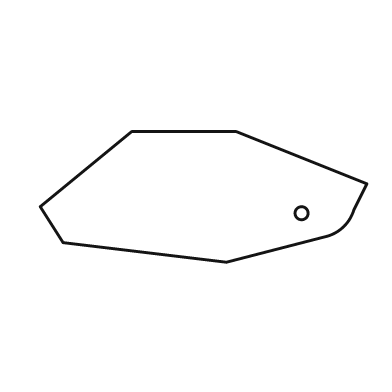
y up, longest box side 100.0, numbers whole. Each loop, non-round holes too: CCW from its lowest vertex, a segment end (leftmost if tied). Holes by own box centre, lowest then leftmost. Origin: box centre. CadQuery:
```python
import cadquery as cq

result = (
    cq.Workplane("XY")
    .moveTo(7.0, -20.0)
    .lineTo(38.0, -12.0)
    .threePointArc((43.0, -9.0), (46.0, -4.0))
    .lineTo(50.0, 4.0)
    .lineTo(10.0, 20.0)
    .lineTo(-22.0, 20.0)
    .lineTo(-50.0, -3.0)
    .lineTo(-43.0, -14.0)
    .close()
    .moveTo(30.0, -5.0)
    .circle(2.0)
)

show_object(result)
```